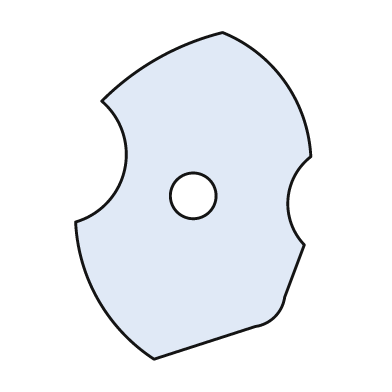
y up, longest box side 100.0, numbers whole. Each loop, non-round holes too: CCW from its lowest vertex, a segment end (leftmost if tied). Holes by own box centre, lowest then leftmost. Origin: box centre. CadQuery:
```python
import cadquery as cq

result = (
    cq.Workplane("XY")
    .moveTo(-12.0, -50.0)
    .lineTo(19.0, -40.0)
    .threePointArc((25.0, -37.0), (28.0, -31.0))
    .lineTo(34.0, -15.0)
    .threePointArc((29.0, -1.0), (36.0, 12.0))
    .threePointArc((28.0, 35.0), (9.0, 50.0))
    .threePointArc((-11.0, 42.0), (-28.0, 29.0))
    .threePointArc((-21.0, 8.0), (-36.0, -8.0))
    .threePointArc((-29.0, -32.0), (-12.0, -50.0))
    .close()
    .moveTo(0.0, 0.0)
    .circle(7.0)
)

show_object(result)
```